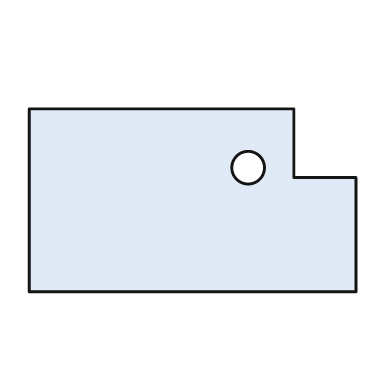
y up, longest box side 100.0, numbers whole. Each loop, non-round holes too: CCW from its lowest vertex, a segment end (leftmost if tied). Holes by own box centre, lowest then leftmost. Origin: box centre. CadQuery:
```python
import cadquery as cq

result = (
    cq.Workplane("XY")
    .moveTo(-50.0, -28.0)
    .lineTo(50.0, -28.0)
    .lineTo(50.0, 7.0)
    .lineTo(31.0, 7.0)
    .lineTo(31.0, 28.0)
    .lineTo(-50.0, 28.0)
    .close()
    .moveTo(17.0, 10.0)
    .circle(5.0)
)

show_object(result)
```